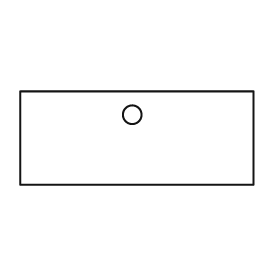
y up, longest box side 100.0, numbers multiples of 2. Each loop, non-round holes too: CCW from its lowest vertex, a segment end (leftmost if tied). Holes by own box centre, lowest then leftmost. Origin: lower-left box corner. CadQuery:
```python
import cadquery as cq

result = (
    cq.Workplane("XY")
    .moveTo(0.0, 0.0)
    .lineTo(100.0, 0.0)
    .lineTo(100.0, 40.0)
    .lineTo(0.0, 40.0)
    .close()
    .moveTo(48.0, 30.0)
    .circle(4.0)
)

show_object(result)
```